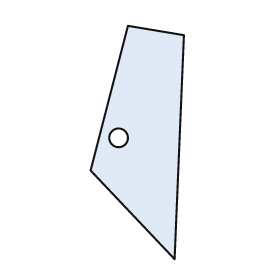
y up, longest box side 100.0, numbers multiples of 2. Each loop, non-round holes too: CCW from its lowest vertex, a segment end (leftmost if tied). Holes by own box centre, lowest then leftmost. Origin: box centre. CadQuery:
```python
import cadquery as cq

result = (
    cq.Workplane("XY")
    .moveTo(16.0, -50.0)
    .lineTo(20.0, 46.0)
    .lineTo(-4.0, 50.0)
    .lineTo(-20.0, -12.0)
    .close()
    .moveTo(-8.0, 2.0)
    .circle(4.0)
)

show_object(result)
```